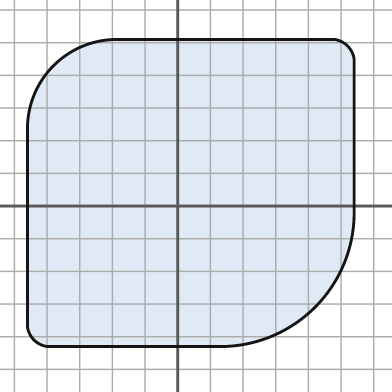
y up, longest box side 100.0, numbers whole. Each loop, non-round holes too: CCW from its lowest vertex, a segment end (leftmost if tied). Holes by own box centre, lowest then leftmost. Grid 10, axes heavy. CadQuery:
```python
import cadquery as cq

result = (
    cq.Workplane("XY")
    .moveTo(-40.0, -43.0)
    .lineTo(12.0, -43.0)
    .threePointArc((42.0, -31.0), (54.0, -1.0))
    .lineTo(54.0, 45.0)
    .threePointArc((52.0, 49.0), (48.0, 51.0))
    .lineTo(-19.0, 51.0)
    .threePointArc((-38.0, 43.0), (-46.0, 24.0))
    .lineTo(-46.0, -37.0)
    .threePointArc((-44.0, -41.0), (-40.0, -43.0))
    .close()
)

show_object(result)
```